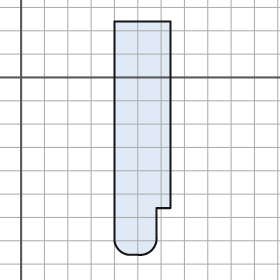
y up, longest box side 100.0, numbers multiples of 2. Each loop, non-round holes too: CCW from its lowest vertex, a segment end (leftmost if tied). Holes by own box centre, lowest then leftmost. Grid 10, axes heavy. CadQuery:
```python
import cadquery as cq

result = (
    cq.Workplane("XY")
    .moveTo(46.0, -76.0)
    .lineTo(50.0, -76.0)
    .threePointArc((56.0, -74.0), (58.0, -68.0))
    .lineTo(58.0, -56.0)
    .lineTo(64.0, -56.0)
    .lineTo(64.0, 24.0)
    .lineTo(40.0, 24.0)
    .lineTo(40.0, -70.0)
    .threePointArc((42.0, -74.0), (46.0, -76.0))
    .close()
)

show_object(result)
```